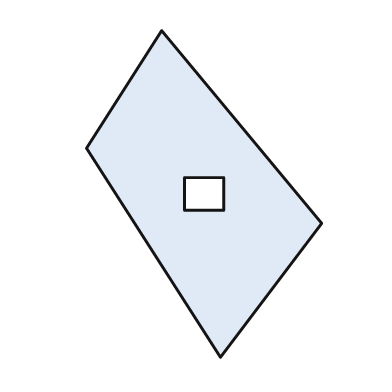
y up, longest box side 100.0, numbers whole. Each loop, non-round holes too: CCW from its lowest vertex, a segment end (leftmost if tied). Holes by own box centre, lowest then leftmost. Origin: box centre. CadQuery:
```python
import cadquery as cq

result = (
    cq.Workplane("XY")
    .moveTo(5.0, -50.0)
    .lineTo(36.0, -9.0)
    .lineTo(-13.0, 50.0)
    .lineTo(-36.0, 14.0)
    .close()
    .moveTo(-6.0, -5.0)
    .lineTo(6.0, -5.0)
    .lineTo(6.0, 5.0)
    .lineTo(-6.0, 5.0)
    .close()
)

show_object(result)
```